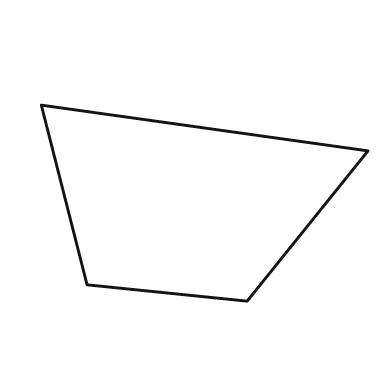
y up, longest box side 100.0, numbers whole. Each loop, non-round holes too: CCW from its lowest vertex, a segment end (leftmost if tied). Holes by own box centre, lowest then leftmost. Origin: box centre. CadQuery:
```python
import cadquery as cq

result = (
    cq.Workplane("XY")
    .moveTo(13.0, -30.0)
    .lineTo(50.0, 16.0)
    .lineTo(-50.0, 30.0)
    .lineTo(-36.0, -25.0)
    .close()
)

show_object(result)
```